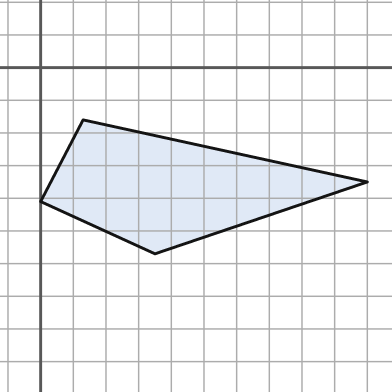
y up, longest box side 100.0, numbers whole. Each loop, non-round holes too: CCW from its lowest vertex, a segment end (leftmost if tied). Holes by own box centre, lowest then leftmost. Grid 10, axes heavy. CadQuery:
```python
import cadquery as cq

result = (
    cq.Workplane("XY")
    .moveTo(35.0, -57.0)
    .lineTo(100.0, -35.0)
    .lineTo(13.0, -16.0)
    .lineTo(0.0, -41.0)
    .close()
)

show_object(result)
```